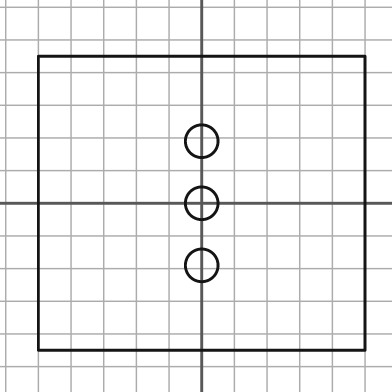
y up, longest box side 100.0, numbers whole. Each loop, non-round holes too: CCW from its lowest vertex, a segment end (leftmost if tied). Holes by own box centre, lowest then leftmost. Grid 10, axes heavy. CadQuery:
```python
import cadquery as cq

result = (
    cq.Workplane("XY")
    .moveTo(-50.0, -45.0)
    .lineTo(50.0, -45.0)
    .lineTo(50.0, 45.0)
    .lineTo(-50.0, 45.0)
    .close()
    .moveTo(0.0, -19.0)
    .circle(5.0)
    .moveTo(0.0, 0.0)
    .circle(5.0)
    .moveTo(0.0, 19.0)
    .circle(5.0)
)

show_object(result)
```